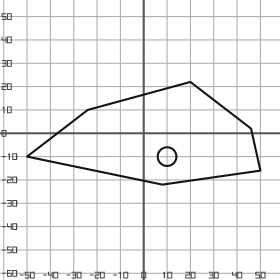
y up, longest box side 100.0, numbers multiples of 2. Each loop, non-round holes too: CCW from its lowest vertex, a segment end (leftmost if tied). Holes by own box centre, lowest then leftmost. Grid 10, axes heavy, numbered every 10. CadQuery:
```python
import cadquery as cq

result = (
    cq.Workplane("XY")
    .moveTo(8.0, -22.0)
    .lineTo(50.0, -16.0)
    .lineTo(46.0, 2.0)
    .lineTo(20.0, 22.0)
    .lineTo(-24.0, 10.0)
    .lineTo(-50.0, -10.0)
    .close()
    .moveTo(10.0, -10.0)
    .circle(4.0)
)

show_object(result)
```